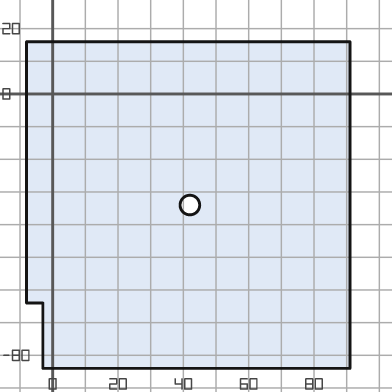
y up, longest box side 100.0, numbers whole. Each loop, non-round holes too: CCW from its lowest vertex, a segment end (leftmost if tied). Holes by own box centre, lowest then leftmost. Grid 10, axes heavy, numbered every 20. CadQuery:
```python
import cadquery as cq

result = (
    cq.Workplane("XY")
    .moveTo(-3.0, -84.0)
    .lineTo(91.0, -84.0)
    .lineTo(91.0, 16.0)
    .lineTo(-8.0, 16.0)
    .lineTo(-8.0, -64.0)
    .lineTo(-3.0, -64.0)
    .close()
    .moveTo(42.0, -34.0)
    .circle(3.0)
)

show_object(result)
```